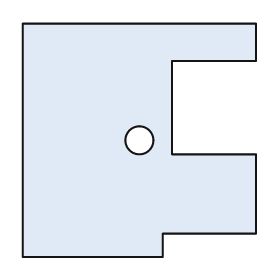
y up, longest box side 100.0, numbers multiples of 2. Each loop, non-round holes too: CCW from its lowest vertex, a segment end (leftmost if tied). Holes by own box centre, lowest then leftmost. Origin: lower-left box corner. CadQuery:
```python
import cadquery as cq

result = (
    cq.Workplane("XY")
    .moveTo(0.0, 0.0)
    .lineTo(60.0, 0.0)
    .lineTo(60.0, 10.0)
    .lineTo(100.0, 10.0)
    .lineTo(100.0, 44.0)
    .lineTo(64.0, 44.0)
    .lineTo(64.0, 84.0)
    .lineTo(100.0, 84.0)
    .lineTo(100.0, 100.0)
    .lineTo(0.0, 100.0)
    .close()
    .moveTo(50.0, 50.0)
    .circle(6.0)
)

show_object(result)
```